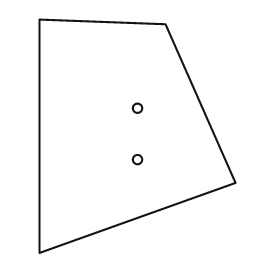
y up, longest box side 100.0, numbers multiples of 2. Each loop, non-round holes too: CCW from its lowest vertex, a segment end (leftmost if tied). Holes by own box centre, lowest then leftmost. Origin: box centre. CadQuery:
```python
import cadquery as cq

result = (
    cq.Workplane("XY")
    .moveTo(-42.0, -50.0)
    .lineTo(42.0, -20.0)
    .lineTo(12.0, 48.0)
    .lineTo(-42.0, 50.0)
    .close()
    .moveTo(0.0, -10.0)
    .circle(2.0)
    .moveTo(0.0, 12.0)
    .circle(2.0)
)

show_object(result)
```